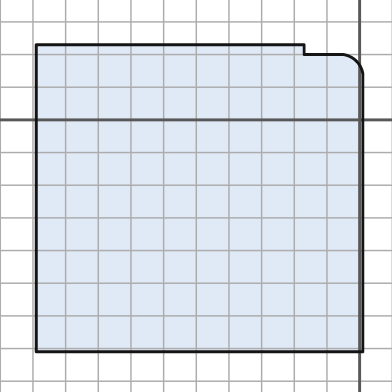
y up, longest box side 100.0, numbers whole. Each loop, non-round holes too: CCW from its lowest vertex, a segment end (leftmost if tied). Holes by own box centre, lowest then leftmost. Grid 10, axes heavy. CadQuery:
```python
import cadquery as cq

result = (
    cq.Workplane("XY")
    .moveTo(-99.0, -71.0)
    .lineTo(1.0, -71.0)
    .lineTo(1.0, 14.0)
    .threePointArc((-1.0, 18.0), (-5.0, 20.0))
    .lineTo(-17.0, 20.0)
    .lineTo(-17.0, 23.0)
    .lineTo(-99.0, 23.0)
    .close()
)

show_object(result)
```